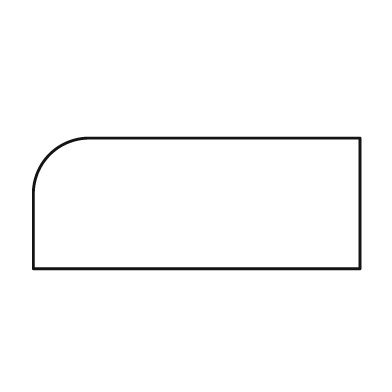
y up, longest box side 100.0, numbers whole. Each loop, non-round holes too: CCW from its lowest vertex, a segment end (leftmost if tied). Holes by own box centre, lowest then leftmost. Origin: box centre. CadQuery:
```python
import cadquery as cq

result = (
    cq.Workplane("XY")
    .moveTo(-50.0, -20.0)
    .lineTo(50.0, -20.0)
    .lineTo(50.0, 20.0)
    .lineTo(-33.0, 20.0)
    .threePointArc((-45.0, 15.0), (-50.0, 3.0))
    .close()
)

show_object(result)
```